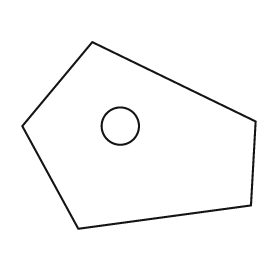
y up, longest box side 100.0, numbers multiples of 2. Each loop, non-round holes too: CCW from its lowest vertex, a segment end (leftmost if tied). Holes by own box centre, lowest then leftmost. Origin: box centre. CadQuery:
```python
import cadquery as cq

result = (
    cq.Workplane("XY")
    .moveTo(-26.0, -40.0)
    .lineTo(48.0, -30.0)
    .lineTo(50.0, 6.0)
    .lineTo(-20.0, 40.0)
    .lineTo(-50.0, 4.0)
    .close()
    .moveTo(-8.0, 4.0)
    .circle(8.0)
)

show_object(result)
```